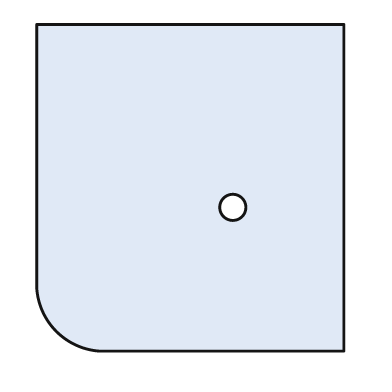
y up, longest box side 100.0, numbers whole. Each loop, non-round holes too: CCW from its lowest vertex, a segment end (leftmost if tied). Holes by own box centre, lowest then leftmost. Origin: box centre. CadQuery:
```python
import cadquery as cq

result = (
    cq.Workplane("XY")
    .moveTo(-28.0, -50.0)
    .lineTo(47.0, -50.0)
    .lineTo(47.0, 50.0)
    .lineTo(-47.0, 50.0)
    .lineTo(-47.0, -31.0)
    .threePointArc((-41.0, -44.0), (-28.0, -50.0))
    .close()
    .moveTo(13.0, -6.0)
    .circle(4.0)
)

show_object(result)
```